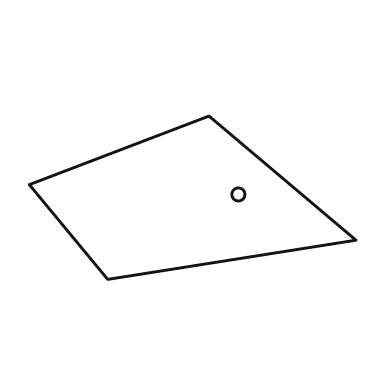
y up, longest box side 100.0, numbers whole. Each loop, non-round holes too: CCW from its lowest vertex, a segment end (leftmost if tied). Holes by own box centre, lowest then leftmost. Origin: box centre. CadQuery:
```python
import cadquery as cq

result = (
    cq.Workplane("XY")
    .moveTo(-26.0, -25.0)
    .lineTo(50.0, -13.0)
    .lineTo(5.0, 25.0)
    .lineTo(-50.0, 4.0)
    .close()
    .moveTo(14.0, 1.0)
    .circle(2.0)
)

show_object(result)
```